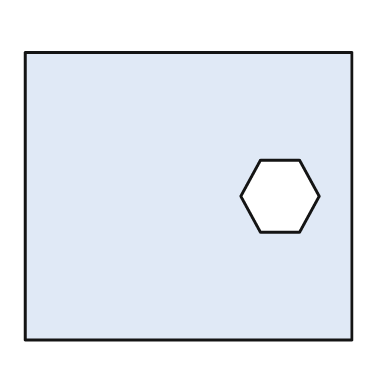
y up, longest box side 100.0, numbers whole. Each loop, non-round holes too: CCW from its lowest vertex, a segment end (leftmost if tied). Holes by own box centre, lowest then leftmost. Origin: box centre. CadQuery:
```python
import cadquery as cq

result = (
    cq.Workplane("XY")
    .moveTo(-50.0, -44.0)
    .lineTo(50.0, -44.0)
    .lineTo(50.0, 44.0)
    .lineTo(-50.0, 44.0)
    .close()
    .moveTo(22.0, -11.0)
    .lineTo(34.0, -11.0)
    .lineTo(40.0, 0.0)
    .lineTo(34.0, 11.0)
    .lineTo(22.0, 11.0)
    .lineTo(16.0, 0.0)
    .close()
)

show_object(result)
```